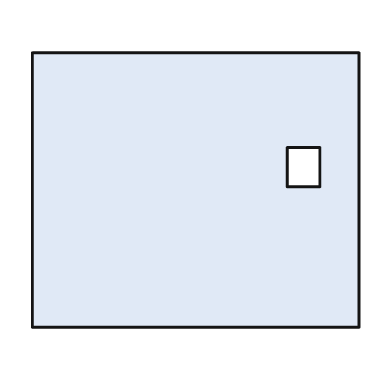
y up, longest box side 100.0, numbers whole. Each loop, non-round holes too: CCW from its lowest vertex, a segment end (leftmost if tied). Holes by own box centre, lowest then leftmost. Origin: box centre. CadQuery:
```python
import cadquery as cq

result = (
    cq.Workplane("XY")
    .moveTo(-50.0, -42.0)
    .lineTo(50.0, -42.0)
    .lineTo(50.0, 42.0)
    .lineTo(-50.0, 42.0)
    .close()
    .moveTo(28.0, 1.0)
    .lineTo(38.0, 1.0)
    .lineTo(38.0, 13.0)
    .lineTo(28.0, 13.0)
    .close()
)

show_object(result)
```